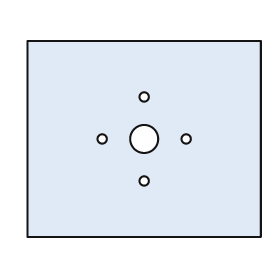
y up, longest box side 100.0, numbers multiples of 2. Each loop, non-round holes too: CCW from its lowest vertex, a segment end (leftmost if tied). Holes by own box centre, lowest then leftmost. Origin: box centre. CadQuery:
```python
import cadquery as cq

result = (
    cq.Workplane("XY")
    .moveTo(-50.0, -42.0)
    .lineTo(50.0, -42.0)
    .lineTo(50.0, 42.0)
    .lineTo(-50.0, 42.0)
    .close()
    .moveTo(0.0, -18.0)
    .circle(2.0)
    .moveTo(-18.0, 0.0)
    .circle(2.0)
    .moveTo(0.0, 0.0)
    .circle(6.0)
    .moveTo(18.0, 0.0)
    .circle(2.0)
    .moveTo(0.0, 18.0)
    .circle(2.0)
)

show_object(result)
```